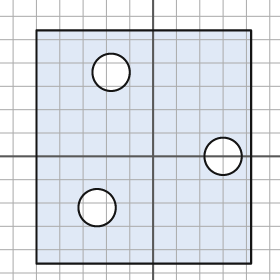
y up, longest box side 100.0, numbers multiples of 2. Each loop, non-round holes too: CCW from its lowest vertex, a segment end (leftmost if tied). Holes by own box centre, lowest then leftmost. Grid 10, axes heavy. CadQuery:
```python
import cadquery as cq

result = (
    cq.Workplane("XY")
    .moveTo(-50.0, -46.0)
    .lineTo(42.0, -46.0)
    .lineTo(42.0, 54.0)
    .lineTo(-50.0, 54.0)
    .close()
    .moveTo(-24.0, -22.0)
    .circle(8.0)
    .moveTo(30.0, 0.0)
    .circle(8.0)
    .moveTo(-18.0, 36.0)
    .circle(8.0)
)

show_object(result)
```